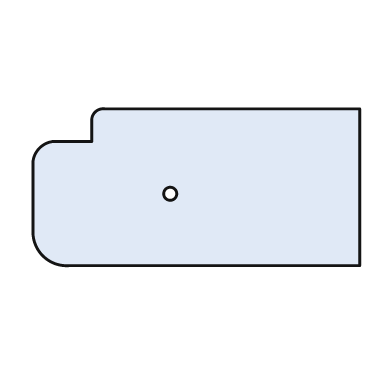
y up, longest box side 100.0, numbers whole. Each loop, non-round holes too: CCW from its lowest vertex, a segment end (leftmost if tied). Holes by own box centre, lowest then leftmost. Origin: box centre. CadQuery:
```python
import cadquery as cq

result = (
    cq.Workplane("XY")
    .moveTo(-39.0, -24.0)
    .lineTo(50.0, -24.0)
    .lineTo(50.0, 24.0)
    .lineTo(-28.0, 24.0)
    .threePointArc((-31.0, 23.0), (-32.0, 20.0))
    .lineTo(-32.0, 14.0)
    .lineTo(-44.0, 14.0)
    .threePointArc((-48.0, 12.0), (-50.0, 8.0))
    .lineTo(-50.0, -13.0)
    .threePointArc((-47.0, -21.0), (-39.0, -24.0))
    .close()
    .moveTo(-8.0, -2.0)
    .circle(2.0)
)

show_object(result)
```